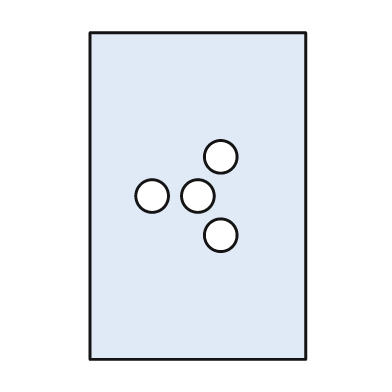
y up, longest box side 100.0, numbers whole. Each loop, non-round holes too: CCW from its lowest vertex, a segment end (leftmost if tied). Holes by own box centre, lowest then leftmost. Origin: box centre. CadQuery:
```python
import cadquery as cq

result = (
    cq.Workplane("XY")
    .moveTo(-33.0, -50.0)
    .lineTo(33.0, -50.0)
    .lineTo(33.0, 50.0)
    .lineTo(-33.0, 50.0)
    .close()
    .moveTo(7.0, -12.0)
    .circle(5.0)
    .moveTo(-14.0, 0.0)
    .circle(5.0)
    .moveTo(0.0, 0.0)
    .circle(5.0)
    .moveTo(7.0, 12.0)
    .circle(5.0)
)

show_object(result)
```